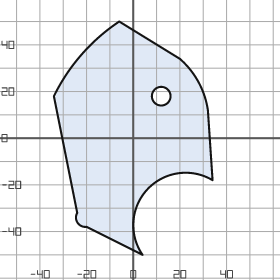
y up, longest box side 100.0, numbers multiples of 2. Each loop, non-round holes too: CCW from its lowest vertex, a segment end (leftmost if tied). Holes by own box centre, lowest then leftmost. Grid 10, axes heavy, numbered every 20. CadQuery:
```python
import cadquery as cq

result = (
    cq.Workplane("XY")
    .moveTo(4.0, -50.0)
    .threePointArc((6.0, -22.0), (34.0, -18.0))
    .lineTo(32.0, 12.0)
    .threePointArc((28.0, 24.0), (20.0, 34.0))
    .lineTo(-6.0, 50.0)
    .threePointArc((-22.0, 36.0), (-34.0, 18.0))
    .lineTo(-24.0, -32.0)
    .threePointArc((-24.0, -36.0), (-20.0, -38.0))
    .close()
    .moveTo(12.0, 18.0)
    .circle(4.0)
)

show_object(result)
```